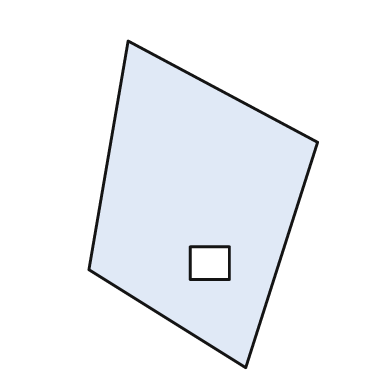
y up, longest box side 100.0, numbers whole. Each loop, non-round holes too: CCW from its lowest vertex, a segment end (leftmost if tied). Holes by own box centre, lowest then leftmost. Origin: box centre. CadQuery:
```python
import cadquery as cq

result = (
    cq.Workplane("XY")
    .moveTo(13.0, -50.0)
    .lineTo(35.0, 19.0)
    .lineTo(-23.0, 50.0)
    .lineTo(-35.0, -20.0)
    .close()
    .moveTo(-4.0, -23.0)
    .lineTo(8.0, -23.0)
    .lineTo(8.0, -13.0)
    .lineTo(-4.0, -13.0)
    .close()
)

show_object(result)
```